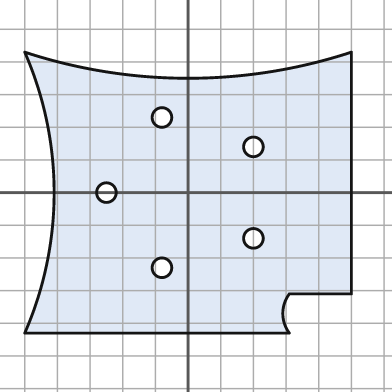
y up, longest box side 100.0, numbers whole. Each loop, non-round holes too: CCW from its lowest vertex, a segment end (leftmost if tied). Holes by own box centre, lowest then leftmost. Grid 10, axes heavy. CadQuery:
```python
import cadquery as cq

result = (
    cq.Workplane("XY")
    .moveTo(-50.0, -43.0)
    .lineTo(31.0, -43.0)
    .threePointArc((29.0, -37.0), (31.0, -31.0))
    .lineTo(50.0, -31.0)
    .lineTo(50.0, 43.0)
    .threePointArc((0.0, 35.0), (-50.0, 43.0))
    .threePointArc((-41.0, 0.0), (-50.0, -43.0))
    .close()
    .moveTo(-8.0, -23.0)
    .circle(3.0)
    .moveTo(20.0, -14.0)
    .circle(3.0)
    .moveTo(-25.0, 0.0)
    .circle(3.0)
    .moveTo(20.0, 14.0)
    .circle(3.0)
    .moveTo(-8.0, 23.0)
    .circle(3.0)
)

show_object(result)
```